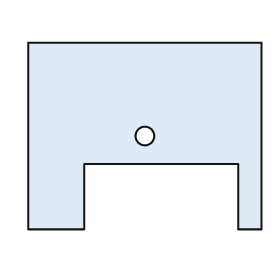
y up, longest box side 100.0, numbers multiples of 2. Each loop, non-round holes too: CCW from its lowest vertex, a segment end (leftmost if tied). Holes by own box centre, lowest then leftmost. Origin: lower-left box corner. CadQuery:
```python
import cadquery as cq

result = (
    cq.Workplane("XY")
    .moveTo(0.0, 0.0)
    .lineTo(24.0, 0.0)
    .lineTo(24.0, 28.0)
    .lineTo(90.0, 28.0)
    .lineTo(90.0, 0.0)
    .lineTo(100.0, 0.0)
    .lineTo(100.0, 80.0)
    .lineTo(0.0, 80.0)
    .close()
    .moveTo(50.0, 40.0)
    .circle(4.0)
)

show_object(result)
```